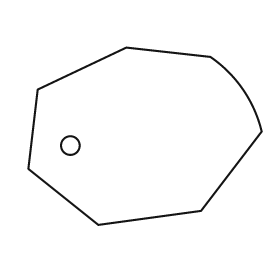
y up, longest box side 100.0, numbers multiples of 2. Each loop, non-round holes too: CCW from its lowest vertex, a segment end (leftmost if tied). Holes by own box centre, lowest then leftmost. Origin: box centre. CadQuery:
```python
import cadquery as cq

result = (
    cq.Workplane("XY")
    .moveTo(-20.0, -38.0)
    .lineTo(24.0, -32.0)
    .lineTo(50.0, 2.0)
    .threePointArc((42.0, 20.0), (28.0, 34.0))
    .lineTo(-8.0, 38.0)
    .lineTo(-46.0, 20.0)
    .lineTo(-50.0, -14.0)
    .close()
    .moveTo(-32.0, -4.0)
    .circle(4.0)
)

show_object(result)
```